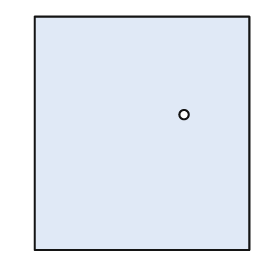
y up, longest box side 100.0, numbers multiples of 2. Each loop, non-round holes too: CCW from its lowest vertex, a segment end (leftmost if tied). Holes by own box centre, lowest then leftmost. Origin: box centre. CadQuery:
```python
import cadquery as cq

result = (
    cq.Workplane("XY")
    .moveTo(-46.0, -50.0)
    .lineTo(46.0, -50.0)
    .lineTo(46.0, 50.0)
    .lineTo(-46.0, 50.0)
    .close()
    .moveTo(18.0, 8.0)
    .circle(2.0)
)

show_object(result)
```